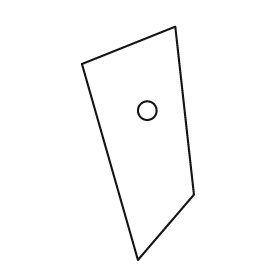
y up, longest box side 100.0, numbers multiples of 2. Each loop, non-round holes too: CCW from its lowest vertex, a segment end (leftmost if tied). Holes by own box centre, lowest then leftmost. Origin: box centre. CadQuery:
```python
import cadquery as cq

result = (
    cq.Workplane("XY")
    .moveTo(0.0, -50.0)
    .lineTo(24.0, -22.0)
    .lineTo(16.0, 50.0)
    .lineTo(-24.0, 34.0)
    .close()
    .moveTo(4.0, 14.0)
    .circle(4.0)
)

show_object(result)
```